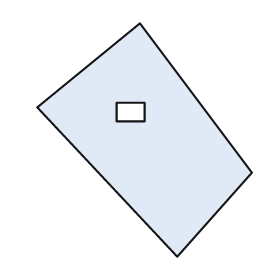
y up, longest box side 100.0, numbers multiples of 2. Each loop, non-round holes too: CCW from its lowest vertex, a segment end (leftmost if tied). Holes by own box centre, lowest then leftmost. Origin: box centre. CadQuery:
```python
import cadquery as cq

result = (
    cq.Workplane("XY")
    .moveTo(14.0, -50.0)
    .lineTo(46.0, -14.0)
    .lineTo(-2.0, 50.0)
    .lineTo(-46.0, 14.0)
    .close()
    .moveTo(-12.0, 8.0)
    .lineTo(0.0, 8.0)
    .lineTo(0.0, 16.0)
    .lineTo(-12.0, 16.0)
    .close()
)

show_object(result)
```